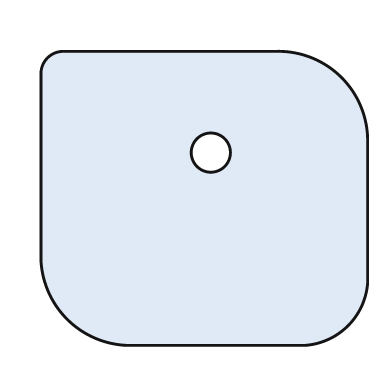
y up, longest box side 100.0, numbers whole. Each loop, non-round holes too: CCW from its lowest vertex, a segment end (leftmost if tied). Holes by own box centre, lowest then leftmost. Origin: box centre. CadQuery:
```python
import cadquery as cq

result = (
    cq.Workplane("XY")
    .moveTo(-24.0, -45.0)
    .lineTo(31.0, -45.0)
    .threePointArc((44.0, -39.0), (50.0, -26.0))
    .lineTo(50.0, 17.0)
    .threePointArc((42.0, 37.0), (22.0, 45.0))
    .lineTo(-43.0, 45.0)
    .threePointArc((-48.0, 43.0), (-50.0, 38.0))
    .lineTo(-50.0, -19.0)
    .threePointArc((-42.0, -37.0), (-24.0, -45.0))
    .close()
    .moveTo(2.0, 14.0)
    .circle(6.0)
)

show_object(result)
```